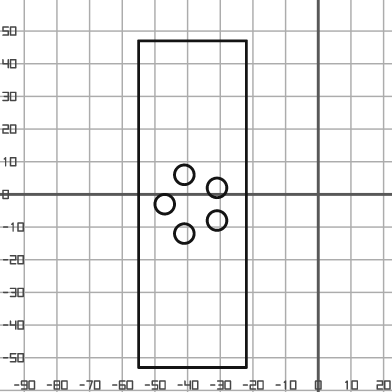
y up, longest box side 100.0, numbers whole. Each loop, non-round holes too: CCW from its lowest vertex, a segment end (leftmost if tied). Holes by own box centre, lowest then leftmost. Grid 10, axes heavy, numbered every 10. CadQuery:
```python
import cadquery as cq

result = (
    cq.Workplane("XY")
    .moveTo(-55.0, -53.0)
    .lineTo(-22.0, -53.0)
    .lineTo(-22.0, 47.0)
    .lineTo(-55.0, 47.0)
    .close()
    .moveTo(-41.0, -12.0)
    .circle(3.0)
    .moveTo(-31.0, -8.0)
    .circle(3.0)
    .moveTo(-47.0, -3.0)
    .circle(3.0)
    .moveTo(-31.0, 2.0)
    .circle(3.0)
    .moveTo(-41.0, 6.0)
    .circle(3.0)
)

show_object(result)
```